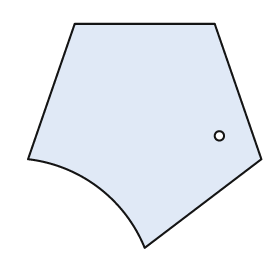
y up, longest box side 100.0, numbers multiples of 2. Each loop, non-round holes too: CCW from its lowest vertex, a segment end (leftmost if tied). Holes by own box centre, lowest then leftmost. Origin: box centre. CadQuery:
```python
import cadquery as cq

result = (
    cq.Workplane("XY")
    .moveTo(0.0, -48.0)
    .lineTo(50.0, -10.0)
    .lineTo(30.0, 48.0)
    .lineTo(-30.0, 48.0)
    .lineTo(-50.0, -10.0)
    .threePointArc((-20.0, -22.0), (0.0, -48.0))
    .close()
    .moveTo(32.0, 0.0)
    .circle(2.0)
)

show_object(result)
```